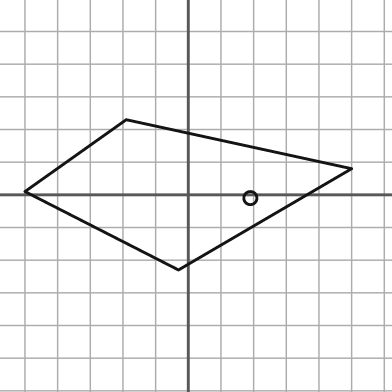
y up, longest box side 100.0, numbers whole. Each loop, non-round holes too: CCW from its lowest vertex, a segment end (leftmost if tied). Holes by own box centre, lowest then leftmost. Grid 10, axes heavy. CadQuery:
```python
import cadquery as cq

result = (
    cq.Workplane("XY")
    .moveTo(-3.0, -23.0)
    .lineTo(50.0, 8.0)
    .lineTo(-19.0, 23.0)
    .lineTo(-50.0, 1.0)
    .close()
    .moveTo(19.0, -1.0)
    .circle(2.0)
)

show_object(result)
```